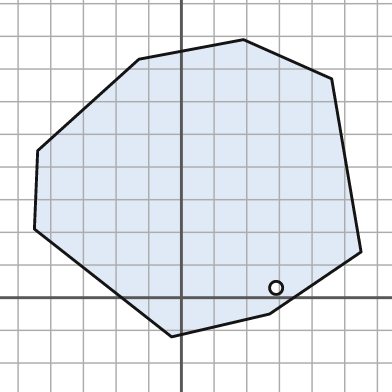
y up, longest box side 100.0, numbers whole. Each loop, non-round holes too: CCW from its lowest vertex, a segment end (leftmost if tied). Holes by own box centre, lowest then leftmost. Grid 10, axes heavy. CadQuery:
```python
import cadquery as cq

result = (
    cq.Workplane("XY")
    .moveTo(-3.0, -12.0)
    .lineTo(27.0, -5.0)
    .lineTo(55.0, 14.0)
    .lineTo(46.0, 67.0)
    .lineTo(19.0, 79.0)
    .lineTo(-13.0, 73.0)
    .lineTo(-44.0, 45.0)
    .lineTo(-45.0, 21.0)
    .close()
    .moveTo(29.0, 3.0)
    .circle(2.0)
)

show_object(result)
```